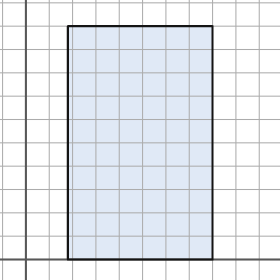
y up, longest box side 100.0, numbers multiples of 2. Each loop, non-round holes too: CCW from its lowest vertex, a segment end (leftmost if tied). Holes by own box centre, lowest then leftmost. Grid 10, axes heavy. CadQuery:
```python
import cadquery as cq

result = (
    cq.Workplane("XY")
    .moveTo(18.0, 0.0)
    .lineTo(80.0, 0.0)
    .lineTo(80.0, 100.0)
    .lineTo(18.0, 100.0)
    .close()
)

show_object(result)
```